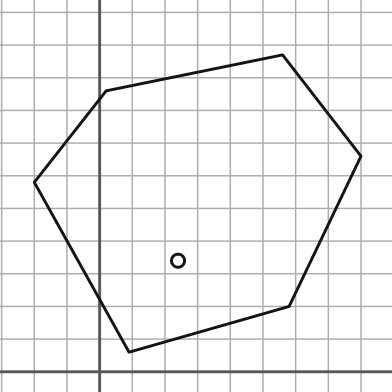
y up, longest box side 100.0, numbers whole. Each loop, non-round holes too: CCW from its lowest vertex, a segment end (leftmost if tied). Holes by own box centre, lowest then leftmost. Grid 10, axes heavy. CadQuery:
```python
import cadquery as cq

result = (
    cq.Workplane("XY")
    .moveTo(9.0, 6.0)
    .lineTo(58.0, 20.0)
    .lineTo(80.0, 66.0)
    .lineTo(56.0, 97.0)
    .lineTo(2.0, 86.0)
    .lineTo(-20.0, 58.0)
    .close()
    .moveTo(24.0, 34.0)
    .circle(2.0)
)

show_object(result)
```